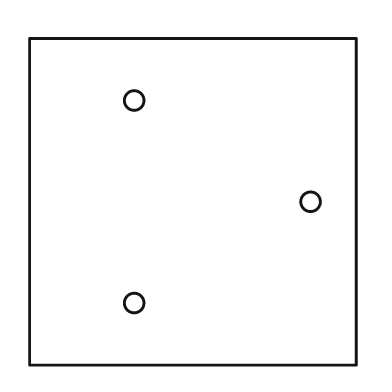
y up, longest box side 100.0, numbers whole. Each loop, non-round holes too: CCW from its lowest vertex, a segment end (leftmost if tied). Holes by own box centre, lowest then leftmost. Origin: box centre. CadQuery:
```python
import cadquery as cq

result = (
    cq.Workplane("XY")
    .moveTo(-50.0, -50.0)
    .lineTo(50.0, -50.0)
    .lineTo(50.0, 50.0)
    .lineTo(-50.0, 50.0)
    .close()
    .moveTo(-18.0, -31.0)
    .circle(3.0)
    .moveTo(36.0, 0.0)
    .circle(3.0)
    .moveTo(-18.0, 31.0)
    .circle(3.0)
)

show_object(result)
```